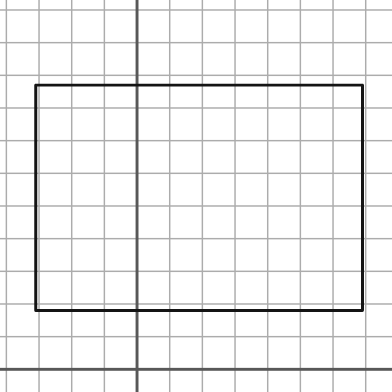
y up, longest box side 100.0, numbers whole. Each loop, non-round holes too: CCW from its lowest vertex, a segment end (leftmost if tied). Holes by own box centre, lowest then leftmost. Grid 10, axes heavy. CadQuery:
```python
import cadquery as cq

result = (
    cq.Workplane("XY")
    .moveTo(-31.0, 18.0)
    .lineTo(69.0, 18.0)
    .lineTo(69.0, 87.0)
    .lineTo(-31.0, 87.0)
    .close()
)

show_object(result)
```